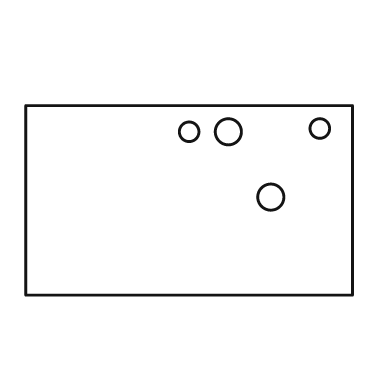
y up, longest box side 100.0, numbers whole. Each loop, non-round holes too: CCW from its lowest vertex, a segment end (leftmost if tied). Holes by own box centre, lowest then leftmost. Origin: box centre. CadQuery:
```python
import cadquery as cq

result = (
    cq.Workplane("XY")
    .moveTo(-50.0, -29.0)
    .lineTo(50.0, -29.0)
    .lineTo(50.0, 29.0)
    .lineTo(-50.0, 29.0)
    .close()
    .moveTo(25.0, 1.0)
    .circle(4.0)
    .moveTo(0.0, 21.0)
    .circle(3.0)
    .moveTo(12.0, 21.0)
    .circle(4.0)
    .moveTo(40.0, 22.0)
    .circle(3.0)
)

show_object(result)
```